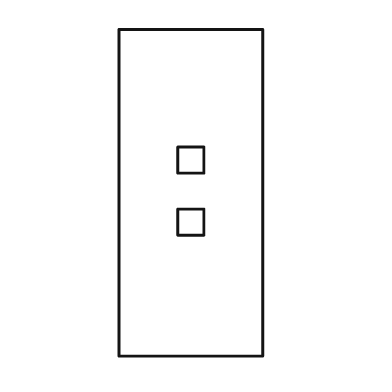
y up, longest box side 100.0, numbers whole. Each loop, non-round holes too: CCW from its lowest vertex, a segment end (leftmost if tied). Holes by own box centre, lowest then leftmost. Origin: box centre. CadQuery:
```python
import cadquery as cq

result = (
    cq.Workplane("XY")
    .moveTo(-22.0, -50.0)
    .lineTo(22.0, -50.0)
    .lineTo(22.0, 50.0)
    .lineTo(-22.0, 50.0)
    .close()
    .moveTo(-4.0, -13.0)
    .lineTo(4.0, -13.0)
    .lineTo(4.0, -5.0)
    .lineTo(-4.0, -5.0)
    .close()
    .moveTo(-4.0, 6.0)
    .lineTo(4.0, 6.0)
    .lineTo(4.0, 14.0)
    .lineTo(-4.0, 14.0)
    .close()
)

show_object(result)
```